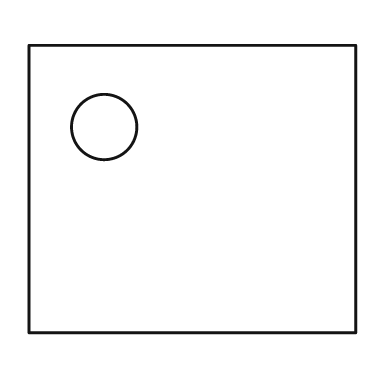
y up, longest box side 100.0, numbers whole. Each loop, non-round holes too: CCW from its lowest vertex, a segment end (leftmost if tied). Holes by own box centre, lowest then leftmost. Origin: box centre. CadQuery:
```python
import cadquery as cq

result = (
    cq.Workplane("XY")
    .moveTo(-50.0, -44.0)
    .lineTo(50.0, -44.0)
    .lineTo(50.0, 44.0)
    .lineTo(-50.0, 44.0)
    .close()
    .moveTo(-27.0, 19.0)
    .circle(10.0)
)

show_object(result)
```